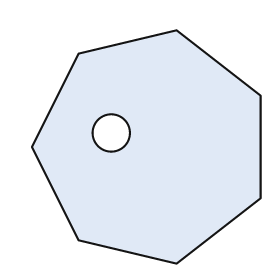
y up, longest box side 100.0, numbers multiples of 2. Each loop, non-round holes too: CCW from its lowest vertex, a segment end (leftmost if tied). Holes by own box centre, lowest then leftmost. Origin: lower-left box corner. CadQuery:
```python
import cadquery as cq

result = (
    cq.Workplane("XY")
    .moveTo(62.0, 0.0)
    .lineTo(98.0, 28.0)
    .lineTo(98.0, 72.0)
    .lineTo(62.0, 100.0)
    .lineTo(20.0, 90.0)
    .lineTo(0.0, 50.0)
    .lineTo(20.0, 10.0)
    .close()
    .moveTo(34.0, 56.0)
    .circle(8.0)
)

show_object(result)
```